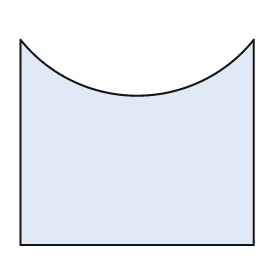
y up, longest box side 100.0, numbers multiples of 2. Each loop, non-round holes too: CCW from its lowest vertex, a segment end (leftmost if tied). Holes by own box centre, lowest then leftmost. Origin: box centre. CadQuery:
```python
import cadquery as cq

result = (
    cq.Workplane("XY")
    .moveTo(-50.0, -44.0)
    .lineTo(50.0, -44.0)
    .lineTo(50.0, 44.0)
    .threePointArc((0.0, 20.0), (-50.0, 44.0))
    .close()
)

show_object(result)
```